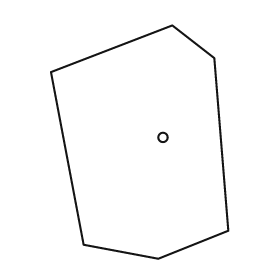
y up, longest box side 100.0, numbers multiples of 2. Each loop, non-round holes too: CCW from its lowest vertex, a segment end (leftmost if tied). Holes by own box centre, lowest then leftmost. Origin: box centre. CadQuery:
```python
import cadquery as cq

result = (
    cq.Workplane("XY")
    .moveTo(8.0, -50.0)
    .lineTo(38.0, -38.0)
    .lineTo(32.0, 36.0)
    .lineTo(14.0, 50.0)
    .lineTo(-38.0, 30.0)
    .lineTo(-24.0, -44.0)
    .close()
    .moveTo(10.0, 2.0)
    .circle(2.0)
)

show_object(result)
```